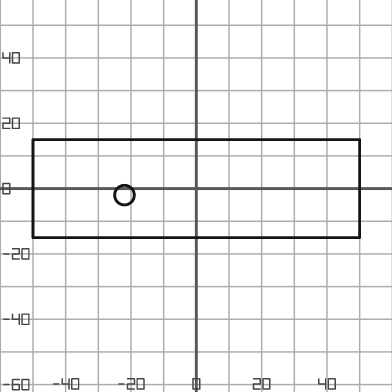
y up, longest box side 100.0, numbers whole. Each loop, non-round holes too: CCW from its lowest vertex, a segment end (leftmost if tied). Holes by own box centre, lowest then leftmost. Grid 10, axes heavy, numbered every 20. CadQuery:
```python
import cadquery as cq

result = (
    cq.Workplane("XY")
    .moveTo(-50.0, -15.0)
    .lineTo(50.0, -15.0)
    .lineTo(50.0, 15.0)
    .lineTo(-50.0, 15.0)
    .close()
    .moveTo(-22.0, -2.0)
    .circle(3.0)
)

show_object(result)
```